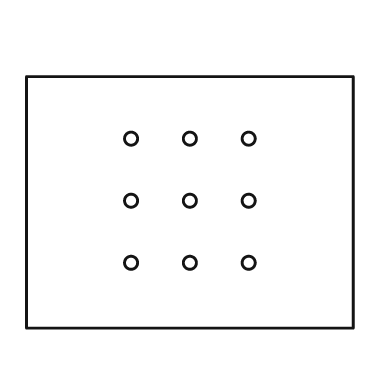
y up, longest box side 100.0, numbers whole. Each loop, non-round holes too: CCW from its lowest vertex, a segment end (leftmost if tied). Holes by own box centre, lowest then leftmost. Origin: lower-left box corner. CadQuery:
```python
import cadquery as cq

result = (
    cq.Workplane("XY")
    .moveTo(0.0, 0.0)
    .lineTo(100.0, 0.0)
    .lineTo(100.0, 77.0)
    .lineTo(0.0, 77.0)
    .close()
    .moveTo(32.0, 20.0)
    .circle(2.0)
    .moveTo(50.0, 20.0)
    .circle(2.0)
    .moveTo(68.0, 20.0)
    .circle(2.0)
    .moveTo(32.0, 39.0)
    .circle(2.0)
    .moveTo(50.0, 39.0)
    .circle(2.0)
    .moveTo(68.0, 39.0)
    .circle(2.0)
    .moveTo(32.0, 58.0)
    .circle(2.0)
    .moveTo(50.0, 58.0)
    .circle(2.0)
    .moveTo(68.0, 58.0)
    .circle(2.0)
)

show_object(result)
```